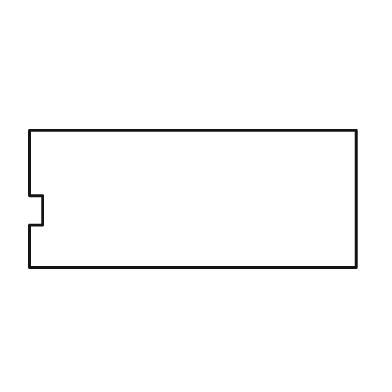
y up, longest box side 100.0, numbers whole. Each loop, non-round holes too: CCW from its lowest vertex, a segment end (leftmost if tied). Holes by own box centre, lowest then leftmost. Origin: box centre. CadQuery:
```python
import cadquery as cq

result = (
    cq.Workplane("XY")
    .moveTo(-50.0, -21.0)
    .lineTo(50.0, -21.0)
    .lineTo(50.0, 21.0)
    .lineTo(-50.0, 21.0)
    .lineTo(-50.0, 1.0)
    .lineTo(-46.0, 1.0)
    .lineTo(-46.0, -8.0)
    .lineTo(-50.0, -8.0)
    .close()
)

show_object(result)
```